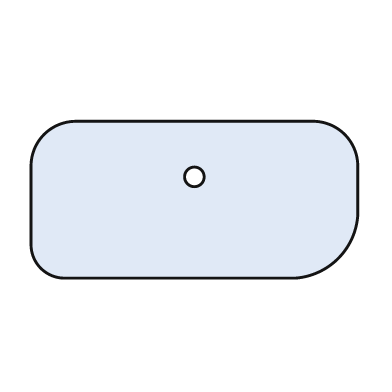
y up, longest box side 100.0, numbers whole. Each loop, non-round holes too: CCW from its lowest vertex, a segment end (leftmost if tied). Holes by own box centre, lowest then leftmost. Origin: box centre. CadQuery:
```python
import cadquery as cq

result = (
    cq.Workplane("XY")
    .moveTo(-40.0, -24.0)
    .lineTo(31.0, -24.0)
    .threePointArc((44.0, -18.0), (50.0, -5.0))
    .lineTo(50.0, 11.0)
    .threePointArc((46.0, 20.0), (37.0, 24.0))
    .lineTo(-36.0, 24.0)
    .threePointArc((-46.0, 20.0), (-50.0, 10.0))
    .lineTo(-50.0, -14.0)
    .threePointArc((-47.0, -21.0), (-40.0, -24.0))
    .close()
    .moveTo(0.0, 7.0)
    .circle(3.0)
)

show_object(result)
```